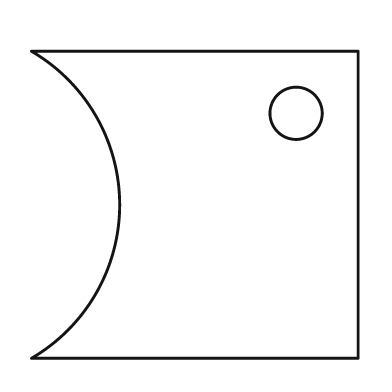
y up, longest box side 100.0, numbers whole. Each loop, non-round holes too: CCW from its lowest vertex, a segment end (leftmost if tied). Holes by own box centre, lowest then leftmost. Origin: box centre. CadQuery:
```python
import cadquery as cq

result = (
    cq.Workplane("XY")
    .moveTo(-50.0, -47.0)
    .lineTo(50.0, -47.0)
    .lineTo(50.0, 47.0)
    .lineTo(-50.0, 47.0)
    .threePointArc((-23.0, 0.0), (-50.0, -47.0))
    .close()
    .moveTo(31.0, 28.0)
    .circle(8.0)
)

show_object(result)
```